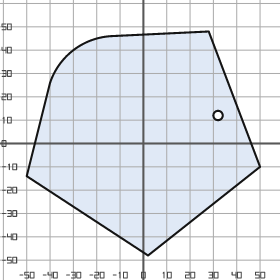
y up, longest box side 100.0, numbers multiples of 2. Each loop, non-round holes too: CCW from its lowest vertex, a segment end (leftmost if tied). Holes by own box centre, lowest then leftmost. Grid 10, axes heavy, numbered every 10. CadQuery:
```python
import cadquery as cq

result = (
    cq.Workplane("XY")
    .moveTo(2.0, -48.0)
    .lineTo(50.0, -10.0)
    .lineTo(28.0, 48.0)
    .lineTo(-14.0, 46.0)
    .threePointArc((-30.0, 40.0), (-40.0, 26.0))
    .lineTo(-50.0, -14.0)
    .close()
    .moveTo(32.0, 12.0)
    .circle(2.0)
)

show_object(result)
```